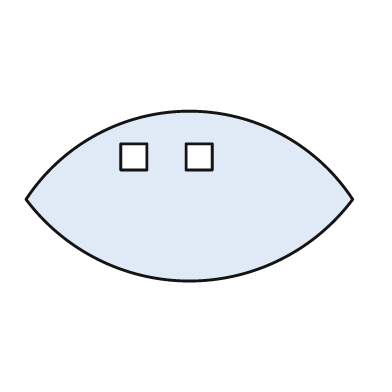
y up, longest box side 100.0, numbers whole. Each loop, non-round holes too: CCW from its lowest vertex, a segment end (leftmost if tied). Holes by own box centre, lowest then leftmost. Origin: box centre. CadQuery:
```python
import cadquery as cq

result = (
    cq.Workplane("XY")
    .moveTo(-50.0, -1.0)
    .threePointArc((0.0, -26.0), (50.0, -1.0))
    .threePointArc((0.0, 26.0), (-50.0, -1.0))
    .close()
    .moveTo(-21.0, 8.0)
    .lineTo(-13.0, 8.0)
    .lineTo(-13.0, 16.0)
    .lineTo(-21.0, 16.0)
    .close()
    .moveTo(-1.0, 8.0)
    .lineTo(7.0, 8.0)
    .lineTo(7.0, 16.0)
    .lineTo(-1.0, 16.0)
    .close()
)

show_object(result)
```